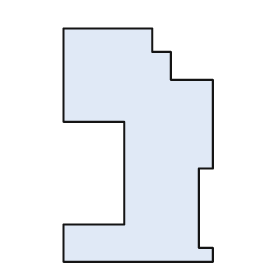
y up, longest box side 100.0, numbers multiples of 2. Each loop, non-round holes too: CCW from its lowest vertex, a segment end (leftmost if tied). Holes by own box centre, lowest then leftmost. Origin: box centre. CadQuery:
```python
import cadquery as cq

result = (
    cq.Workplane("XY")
    .moveTo(-32.0, -50.0)
    .lineTo(32.0, -50.0)
    .lineTo(32.0, -44.0)
    .lineTo(26.0, -44.0)
    .lineTo(26.0, -10.0)
    .lineTo(32.0, -10.0)
    .lineTo(32.0, 28.0)
    .lineTo(14.0, 28.0)
    .lineTo(14.0, 40.0)
    .lineTo(6.0, 40.0)
    .lineTo(6.0, 50.0)
    .lineTo(-32.0, 50.0)
    .lineTo(-32.0, 10.0)
    .lineTo(-6.0, 10.0)
    .lineTo(-6.0, -34.0)
    .lineTo(-32.0, -34.0)
    .close()
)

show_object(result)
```